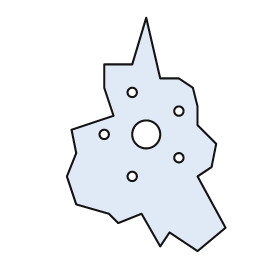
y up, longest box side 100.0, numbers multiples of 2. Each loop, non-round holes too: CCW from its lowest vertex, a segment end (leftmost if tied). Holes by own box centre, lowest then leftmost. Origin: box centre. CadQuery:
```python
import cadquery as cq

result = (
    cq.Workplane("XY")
    .moveTo(22.0, -50.0)
    .lineTo(34.0, -40.0)
    .lineTo(22.0, -18.0)
    .lineTo(28.0, -14.0)
    .lineTo(30.0, -4.0)
    .lineTo(22.0, 4.0)
    .lineTo(22.0, 12.0)
    .lineTo(20.0, 20.0)
    .lineTo(14.0, 24.0)
    .lineTo(6.0, 24.0)
    .lineTo(0.0, 50.0)
    .lineTo(-6.0, 30.0)
    .lineTo(-18.0, 30.0)
    .lineTo(-18.0, 20.0)
    .lineTo(-14.0, 8.0)
    .lineTo(-32.0, 2.0)
    .lineTo(-30.0, -8.0)
    .lineTo(-34.0, -18.0)
    .lineTo(-30.0, -30.0)
    .lineTo(-16.0, -34.0)
    .lineTo(-12.0, -38.0)
    .lineTo(-2.0, -34.0)
    .lineTo(6.0, -48.0)
    .lineTo(10.0, -42.0)
    .close()
    .moveTo(-6.0, -18.0)
    .circle(2.0)
    .moveTo(14.0, -10.0)
    .circle(2.0)
    .moveTo(-18.0, 0.0)
    .circle(2.0)
    .moveTo(0.0, 0.0)
    .circle(6.0)
    .moveTo(14.0, 10.0)
    .circle(2.0)
    .moveTo(-6.0, 18.0)
    .circle(2.0)
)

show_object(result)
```